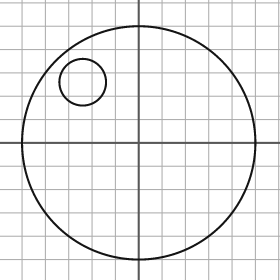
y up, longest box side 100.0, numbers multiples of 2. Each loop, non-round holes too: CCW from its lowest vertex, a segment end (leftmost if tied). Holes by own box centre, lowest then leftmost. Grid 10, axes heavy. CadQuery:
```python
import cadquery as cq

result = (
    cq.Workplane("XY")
    .moveTo(0.0, 0.0)
    .circle(50.0)
    .moveTo(-24.0, 26.0)
    .circle(10.0)
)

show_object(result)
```